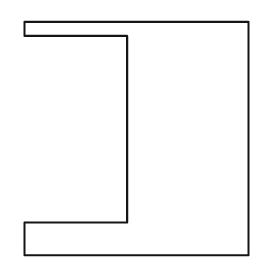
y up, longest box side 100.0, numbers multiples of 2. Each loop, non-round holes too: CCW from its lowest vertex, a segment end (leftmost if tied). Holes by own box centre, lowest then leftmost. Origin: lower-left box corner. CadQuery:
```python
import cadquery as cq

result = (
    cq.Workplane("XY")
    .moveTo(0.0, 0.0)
    .lineTo(96.0, 0.0)
    .lineTo(96.0, 100.0)
    .lineTo(0.0, 100.0)
    .lineTo(0.0, 94.0)
    .lineTo(44.0, 94.0)
    .lineTo(44.0, 14.0)
    .lineTo(0.0, 14.0)
    .close()
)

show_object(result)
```